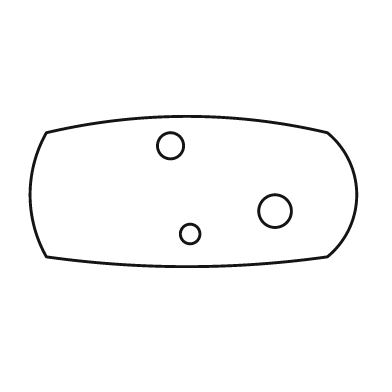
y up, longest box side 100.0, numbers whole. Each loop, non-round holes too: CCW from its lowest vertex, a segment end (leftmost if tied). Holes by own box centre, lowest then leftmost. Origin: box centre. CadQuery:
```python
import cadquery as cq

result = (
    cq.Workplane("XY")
    .moveTo(-45.0, -20.0)
    .threePointArc((-2.0, -23.0), (41.0, -20.0))
    .threePointArc((50.0, -1.0), (41.0, 18.0))
    .threePointArc((-2.0, 23.0), (-45.0, 18.0))
    .threePointArc((-50.0, -1.0), (-45.0, -20.0))
    .close()
    .moveTo(-1.0, -13.0)
    .circle(3.0)
    .moveTo(25.0, -6.0)
    .circle(5.0)
    .moveTo(-7.0, 14.0)
    .circle(4.0)
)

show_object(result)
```